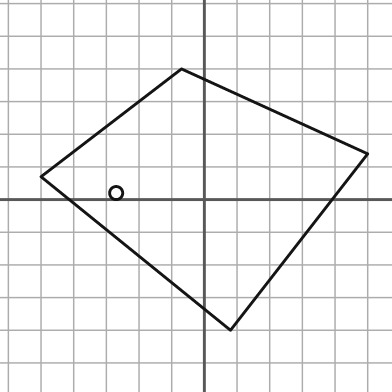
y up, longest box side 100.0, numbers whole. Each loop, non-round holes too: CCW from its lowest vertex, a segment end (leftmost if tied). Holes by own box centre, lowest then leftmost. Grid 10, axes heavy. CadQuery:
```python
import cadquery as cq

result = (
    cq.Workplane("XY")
    .moveTo(8.0, -40.0)
    .lineTo(50.0, 14.0)
    .lineTo(-7.0, 40.0)
    .lineTo(-50.0, 7.0)
    .close()
    .moveTo(-27.0, 2.0)
    .circle(2.0)
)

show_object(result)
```